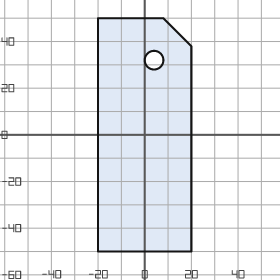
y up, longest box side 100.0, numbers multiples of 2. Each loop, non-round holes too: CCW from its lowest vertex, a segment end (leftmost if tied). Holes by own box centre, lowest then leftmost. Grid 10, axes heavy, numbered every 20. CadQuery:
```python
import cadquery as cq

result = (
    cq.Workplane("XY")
    .moveTo(-20.0, -50.0)
    .lineTo(20.0, -50.0)
    .lineTo(20.0, 38.0)
    .lineTo(8.0, 50.0)
    .lineTo(-20.0, 50.0)
    .close()
    .moveTo(4.0, 32.0)
    .circle(4.0)
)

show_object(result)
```